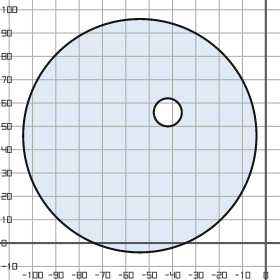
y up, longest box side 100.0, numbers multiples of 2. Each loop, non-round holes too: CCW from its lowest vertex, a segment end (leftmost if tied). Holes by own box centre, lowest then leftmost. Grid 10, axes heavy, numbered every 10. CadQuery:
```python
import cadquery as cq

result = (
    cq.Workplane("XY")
    .moveTo(-54.0, 46.0)
    .circle(50.0)
    .moveTo(-42.0, 56.0)
    .circle(6.0)
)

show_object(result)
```